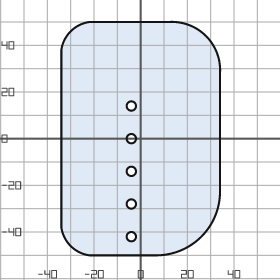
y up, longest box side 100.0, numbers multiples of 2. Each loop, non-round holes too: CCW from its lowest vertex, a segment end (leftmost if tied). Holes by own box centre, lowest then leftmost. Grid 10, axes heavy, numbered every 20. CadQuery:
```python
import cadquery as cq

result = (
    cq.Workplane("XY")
    .moveTo(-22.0, -50.0)
    .lineTo(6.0, -50.0)
    .threePointArc((26.0, -42.0), (34.0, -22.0))
    .lineTo(34.0, 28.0)
    .threePointArc((28.0, 44.0), (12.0, 50.0))
    .lineTo(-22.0, 50.0)
    .threePointArc((-30.0, 46.0), (-34.0, 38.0))
    .lineTo(-34.0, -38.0)
    .threePointArc((-30.0, -46.0), (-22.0, -50.0))
    .close()
    .moveTo(-4.0, -42.0)
    .circle(2.0)
    .moveTo(-4.0, -28.0)
    .circle(2.0)
    .moveTo(-4.0, -14.0)
    .circle(2.0)
    .moveTo(-4.0, 0.0)
    .circle(2.0)
    .moveTo(-4.0, 14.0)
    .circle(2.0)
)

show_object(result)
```